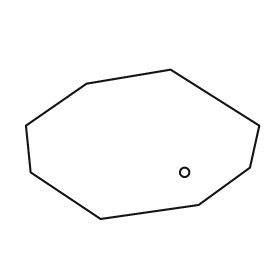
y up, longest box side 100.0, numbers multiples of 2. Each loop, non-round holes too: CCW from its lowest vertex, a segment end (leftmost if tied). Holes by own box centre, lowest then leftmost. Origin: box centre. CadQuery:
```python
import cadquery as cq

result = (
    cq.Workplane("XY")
    .moveTo(-18.0, -32.0)
    .lineTo(24.0, -26.0)
    .lineTo(46.0, -10.0)
    .lineTo(50.0, 8.0)
    .lineTo(12.0, 32.0)
    .lineTo(-24.0, 26.0)
    .lineTo(-50.0, 8.0)
    .lineTo(-48.0, -12.0)
    .close()
    .moveTo(18.0, -12.0)
    .circle(2.0)
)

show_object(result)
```